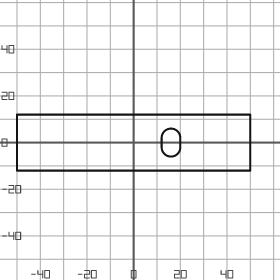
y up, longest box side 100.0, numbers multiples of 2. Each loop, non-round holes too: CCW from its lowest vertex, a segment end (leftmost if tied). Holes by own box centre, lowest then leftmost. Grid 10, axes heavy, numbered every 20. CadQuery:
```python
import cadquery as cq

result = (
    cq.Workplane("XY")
    .moveTo(-50.0, -12.0)
    .lineTo(50.0, -12.0)
    .lineTo(50.0, 12.0)
    .lineTo(-50.0, 12.0)
    .close()
    .moveTo(12.0, -2.0)
    .threePointArc((16.0, -6.0), (20.0, -2.0))
    .lineTo(20.0, 2.0)
    .threePointArc((16.0, 6.0), (12.0, 2.0))
    .close()
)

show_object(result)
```